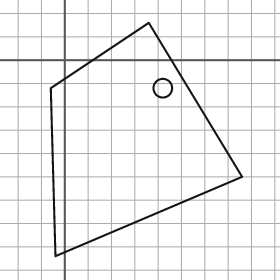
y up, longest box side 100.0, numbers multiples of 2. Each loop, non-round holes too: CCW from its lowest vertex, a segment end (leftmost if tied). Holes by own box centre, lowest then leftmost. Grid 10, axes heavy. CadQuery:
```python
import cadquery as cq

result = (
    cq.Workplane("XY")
    .moveTo(-4.0, -84.0)
    .lineTo(76.0, -50.0)
    .lineTo(36.0, 16.0)
    .lineTo(-6.0, -12.0)
    .close()
    .moveTo(42.0, -12.0)
    .circle(4.0)
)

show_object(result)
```